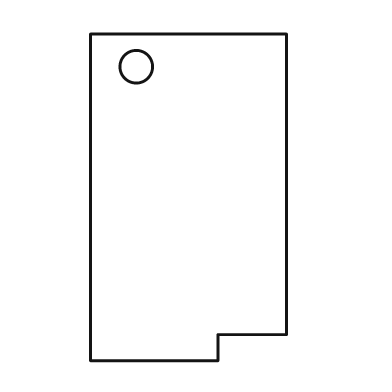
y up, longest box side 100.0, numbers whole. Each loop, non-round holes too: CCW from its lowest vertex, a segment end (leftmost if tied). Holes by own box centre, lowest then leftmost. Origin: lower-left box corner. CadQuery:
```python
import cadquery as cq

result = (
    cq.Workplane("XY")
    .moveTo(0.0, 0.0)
    .lineTo(39.0, 0.0)
    .lineTo(39.0, 8.0)
    .lineTo(60.0, 8.0)
    .lineTo(60.0, 100.0)
    .lineTo(0.0, 100.0)
    .close()
    .moveTo(14.0, 90.0)
    .circle(5.0)
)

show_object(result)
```